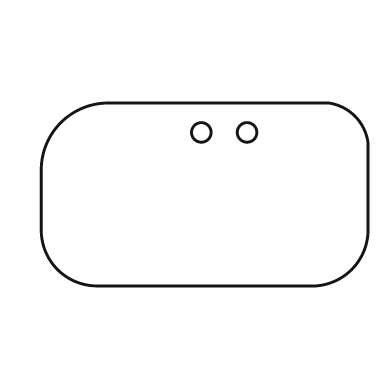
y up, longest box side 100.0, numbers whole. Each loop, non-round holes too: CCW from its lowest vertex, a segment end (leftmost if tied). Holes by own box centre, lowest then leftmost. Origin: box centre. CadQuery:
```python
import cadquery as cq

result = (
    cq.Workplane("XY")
    .moveTo(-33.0, -28.0)
    .lineTo(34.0, -28.0)
    .threePointArc((45.0, -23.0), (50.0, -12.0))
    .lineTo(50.0, 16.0)
    .threePointArc((46.0, 24.0), (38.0, 28.0))
    .lineTo(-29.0, 28.0)
    .threePointArc((-44.0, 22.0), (-50.0, 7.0))
    .lineTo(-50.0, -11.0)
    .threePointArc((-45.0, -23.0), (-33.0, -28.0))
    .close()
    .moveTo(-1.0, 19.0)
    .circle(3.0)
    .moveTo(13.0, 19.0)
    .circle(3.0)
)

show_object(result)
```